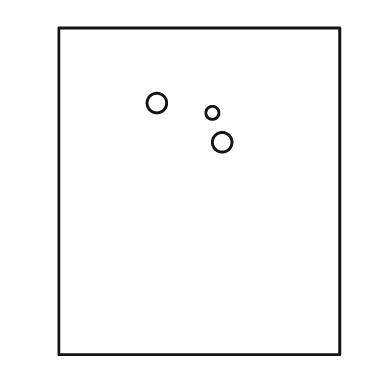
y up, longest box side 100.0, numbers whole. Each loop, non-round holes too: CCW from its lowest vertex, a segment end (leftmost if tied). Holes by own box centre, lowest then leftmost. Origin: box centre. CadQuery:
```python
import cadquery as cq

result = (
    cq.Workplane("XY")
    .moveTo(-43.0, -50.0)
    .lineTo(43.0, -50.0)
    .lineTo(43.0, 50.0)
    .lineTo(-43.0, 50.0)
    .close()
    .moveTo(7.0, 15.0)
    .circle(3.0)
    .moveTo(4.0, 24.0)
    .circle(2.0)
    .moveTo(-13.0, 27.0)
    .circle(3.0)
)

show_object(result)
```